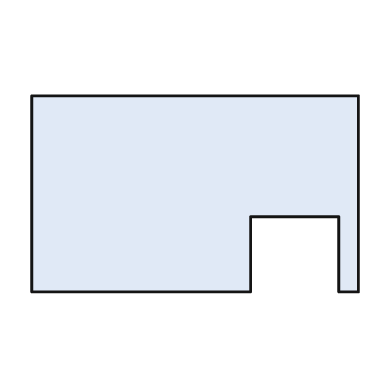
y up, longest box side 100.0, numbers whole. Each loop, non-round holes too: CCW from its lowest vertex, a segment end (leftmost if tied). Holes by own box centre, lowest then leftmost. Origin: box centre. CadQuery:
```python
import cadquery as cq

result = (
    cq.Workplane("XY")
    .moveTo(-50.0, -30.0)
    .lineTo(17.0, -30.0)
    .lineTo(17.0, -7.0)
    .lineTo(44.0, -7.0)
    .lineTo(44.0, -30.0)
    .lineTo(50.0, -30.0)
    .lineTo(50.0, 30.0)
    .lineTo(-50.0, 30.0)
    .close()
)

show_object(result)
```